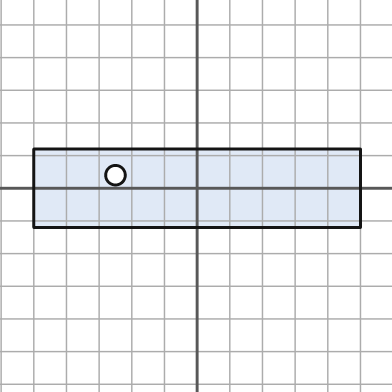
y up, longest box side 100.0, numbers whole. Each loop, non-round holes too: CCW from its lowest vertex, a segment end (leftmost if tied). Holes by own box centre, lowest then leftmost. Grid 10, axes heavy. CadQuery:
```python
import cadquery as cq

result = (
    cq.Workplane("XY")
    .moveTo(-50.0, -12.0)
    .lineTo(50.0, -12.0)
    .lineTo(50.0, 12.0)
    .lineTo(-50.0, 12.0)
    .close()
    .moveTo(-25.0, 4.0)
    .circle(3.0)
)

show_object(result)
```